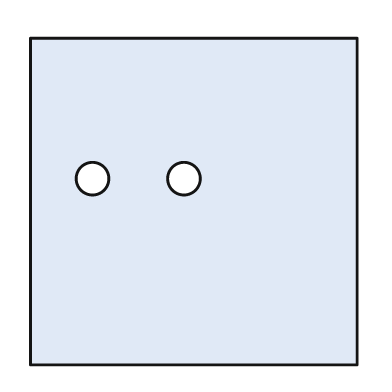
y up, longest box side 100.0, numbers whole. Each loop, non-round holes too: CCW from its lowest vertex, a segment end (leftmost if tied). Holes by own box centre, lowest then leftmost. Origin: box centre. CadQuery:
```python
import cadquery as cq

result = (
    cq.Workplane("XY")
    .moveTo(-50.0, -50.0)
    .lineTo(50.0, -50.0)
    .lineTo(50.0, 50.0)
    .lineTo(-50.0, 50.0)
    .close()
    .moveTo(-31.0, 7.0)
    .circle(5.0)
    .moveTo(-3.0, 7.0)
    .circle(5.0)
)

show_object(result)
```